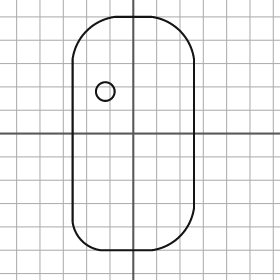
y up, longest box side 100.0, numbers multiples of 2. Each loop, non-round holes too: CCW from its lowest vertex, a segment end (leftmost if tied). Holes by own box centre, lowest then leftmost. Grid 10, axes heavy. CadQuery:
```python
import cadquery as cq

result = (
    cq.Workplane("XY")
    .moveTo(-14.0, -50.0)
    .lineTo(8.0, -50.0)
    .threePointArc((20.0, -44.0), (26.0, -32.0))
    .lineTo(26.0, 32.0)
    .threePointArc((20.0, 44.0), (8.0, 50.0))
    .lineTo(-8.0, 50.0)
    .threePointArc((-20.0, 44.0), (-26.0, 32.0))
    .lineTo(-26.0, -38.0)
    .threePointArc((-22.0, -46.0), (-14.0, -50.0))
    .close()
    .moveTo(-12.0, 18.0)
    .circle(4.0)
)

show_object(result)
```